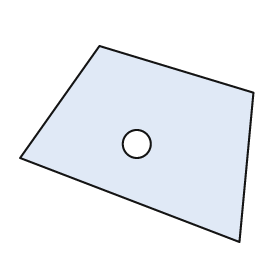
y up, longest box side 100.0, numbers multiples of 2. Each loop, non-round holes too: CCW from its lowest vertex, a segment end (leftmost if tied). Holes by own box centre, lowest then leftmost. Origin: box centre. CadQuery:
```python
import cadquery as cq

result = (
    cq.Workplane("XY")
    .moveTo(44.0, -42.0)
    .lineTo(50.0, 22.0)
    .lineTo(-16.0, 42.0)
    .lineTo(-50.0, -6.0)
    .close()
    .moveTo(0.0, 0.0)
    .circle(6.0)
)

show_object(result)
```